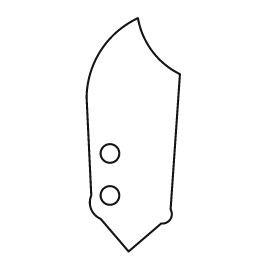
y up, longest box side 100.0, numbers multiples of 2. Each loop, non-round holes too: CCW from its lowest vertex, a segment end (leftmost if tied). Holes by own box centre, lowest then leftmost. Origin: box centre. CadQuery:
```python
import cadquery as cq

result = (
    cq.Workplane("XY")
    .moveTo(-2.0, -50.0)
    .lineTo(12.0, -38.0)
    .threePointArc((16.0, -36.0), (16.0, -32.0))
    .lineTo(20.0, 26.0)
    .threePointArc((8.0, 36.0), (2.0, 50.0))
    .threePointArc((-14.0, 36.0), (-20.0, 16.0))
    .lineTo(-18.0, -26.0)
    .threePointArc((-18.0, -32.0), (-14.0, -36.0))
    .close()
    .moveTo(-10.0, -26.0)
    .circle(4.0)
    .moveTo(-10.0, -8.0)
    .circle(4.0)
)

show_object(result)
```